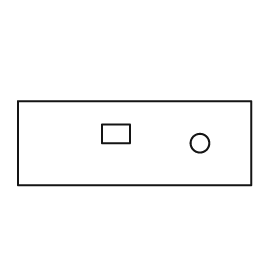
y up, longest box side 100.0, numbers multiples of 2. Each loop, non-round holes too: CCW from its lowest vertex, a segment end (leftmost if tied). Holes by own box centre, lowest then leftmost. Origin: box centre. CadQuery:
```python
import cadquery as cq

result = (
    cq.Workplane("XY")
    .moveTo(-50.0, -18.0)
    .lineTo(50.0, -18.0)
    .lineTo(50.0, 18.0)
    .lineTo(-50.0, 18.0)
    .close()
    .moveTo(28.0, 0.0)
    .circle(4.0)
    .moveTo(-14.0, 0.0)
    .lineTo(-2.0, 0.0)
    .lineTo(-2.0, 8.0)
    .lineTo(-14.0, 8.0)
    .close()
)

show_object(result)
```